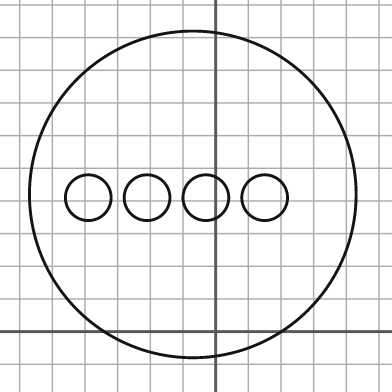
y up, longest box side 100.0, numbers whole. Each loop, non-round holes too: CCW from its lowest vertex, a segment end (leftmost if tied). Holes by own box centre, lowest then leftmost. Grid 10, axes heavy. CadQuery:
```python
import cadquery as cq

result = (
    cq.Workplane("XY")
    .moveTo(-7.0, 42.0)
    .circle(50.0)
    .moveTo(-39.0, 41.0)
    .circle(7.0)
    .moveTo(-21.0, 41.0)
    .circle(7.0)
    .moveTo(-3.0, 41.0)
    .circle(7.0)
    .moveTo(15.0, 41.0)
    .circle(7.0)
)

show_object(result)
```